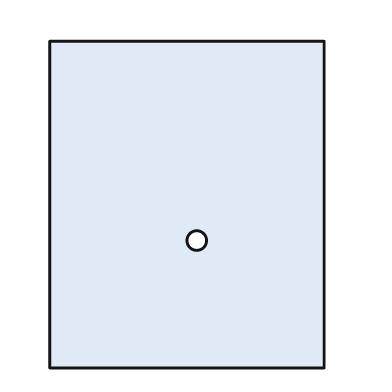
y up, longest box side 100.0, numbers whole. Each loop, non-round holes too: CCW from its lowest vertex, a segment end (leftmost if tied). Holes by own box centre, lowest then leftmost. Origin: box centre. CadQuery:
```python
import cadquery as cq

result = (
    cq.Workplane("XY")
    .moveTo(-42.0, -50.0)
    .lineTo(42.0, -50.0)
    .lineTo(42.0, 50.0)
    .lineTo(-42.0, 50.0)
    .close()
    .moveTo(3.0, -11.0)
    .circle(3.0)
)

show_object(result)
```